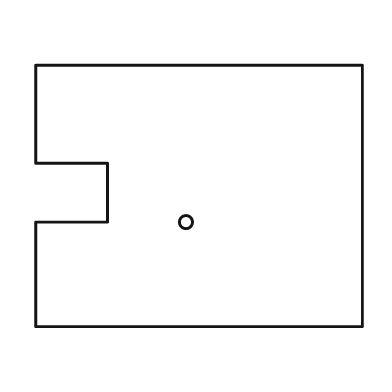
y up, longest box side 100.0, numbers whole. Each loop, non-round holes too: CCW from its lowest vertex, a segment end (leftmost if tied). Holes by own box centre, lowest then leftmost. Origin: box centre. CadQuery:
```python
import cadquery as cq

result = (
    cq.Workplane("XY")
    .moveTo(-50.0, -40.0)
    .lineTo(50.0, -40.0)
    .lineTo(50.0, 40.0)
    .lineTo(-50.0, 40.0)
    .lineTo(-50.0, 10.0)
    .lineTo(-28.0, 10.0)
    .lineTo(-28.0, -8.0)
    .lineTo(-50.0, -8.0)
    .close()
    .moveTo(-4.0, -8.0)
    .circle(2.0)
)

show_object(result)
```